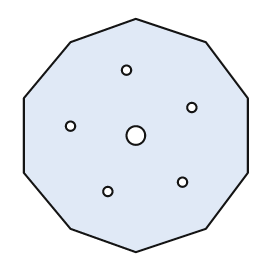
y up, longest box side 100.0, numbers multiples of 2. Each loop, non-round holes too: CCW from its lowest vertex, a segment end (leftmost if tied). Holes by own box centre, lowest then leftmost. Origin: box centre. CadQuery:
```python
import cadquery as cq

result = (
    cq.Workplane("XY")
    .moveTo(0.0, -50.0)
    .lineTo(30.0, -40.0)
    .lineTo(48.0, -16.0)
    .lineTo(48.0, 16.0)
    .lineTo(30.0, 40.0)
    .lineTo(0.0, 50.0)
    .lineTo(-28.0, 40.0)
    .lineTo(-48.0, 16.0)
    .lineTo(-48.0, -16.0)
    .lineTo(-28.0, -40.0)
    .close()
    .moveTo(-12.0, -24.0)
    .circle(2.0)
    .moveTo(20.0, -20.0)
    .circle(2.0)
    .moveTo(0.0, 0.0)
    .circle(4.0)
    .moveTo(-28.0, 4.0)
    .circle(2.0)
    .moveTo(24.0, 12.0)
    .circle(2.0)
    .moveTo(-4.0, 28.0)
    .circle(2.0)
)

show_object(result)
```